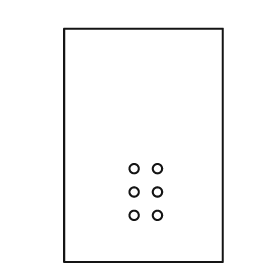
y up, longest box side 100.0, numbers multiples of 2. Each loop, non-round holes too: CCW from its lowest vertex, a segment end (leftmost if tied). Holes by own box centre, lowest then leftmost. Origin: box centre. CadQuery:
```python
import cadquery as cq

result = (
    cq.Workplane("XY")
    .moveTo(-34.0, -50.0)
    .lineTo(34.0, -50.0)
    .lineTo(34.0, 50.0)
    .lineTo(-34.0, 50.0)
    .close()
    .moveTo(-4.0, -30.0)
    .circle(2.0)
    .moveTo(6.0, -30.0)
    .circle(2.0)
    .moveTo(-4.0, -20.0)
    .circle(2.0)
    .moveTo(6.0, -20.0)
    .circle(2.0)
    .moveTo(-4.0, -10.0)
    .circle(2.0)
    .moveTo(6.0, -10.0)
    .circle(2.0)
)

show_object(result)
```